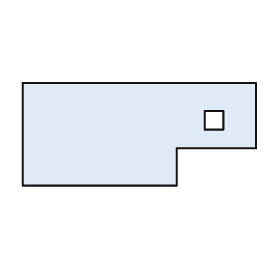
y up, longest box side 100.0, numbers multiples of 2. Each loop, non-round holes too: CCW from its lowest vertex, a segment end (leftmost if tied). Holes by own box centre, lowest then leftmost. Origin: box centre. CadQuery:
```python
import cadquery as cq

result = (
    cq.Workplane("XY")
    .moveTo(-50.0, -22.0)
    .lineTo(16.0, -22.0)
    .lineTo(16.0, -6.0)
    .lineTo(50.0, -6.0)
    .lineTo(50.0, 22.0)
    .lineTo(-50.0, 22.0)
    .close()
    .moveTo(28.0, 2.0)
    .lineTo(36.0, 2.0)
    .lineTo(36.0, 10.0)
    .lineTo(28.0, 10.0)
    .close()
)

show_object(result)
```